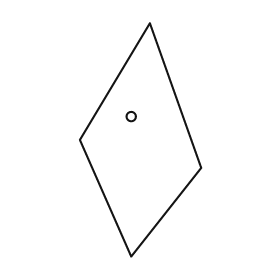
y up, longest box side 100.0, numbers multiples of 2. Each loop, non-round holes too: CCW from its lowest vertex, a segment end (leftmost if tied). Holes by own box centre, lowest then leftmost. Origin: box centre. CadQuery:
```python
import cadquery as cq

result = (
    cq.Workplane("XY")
    .moveTo(-4.0, -50.0)
    .lineTo(26.0, -12.0)
    .lineTo(4.0, 50.0)
    .lineTo(-26.0, 0.0)
    .close()
    .moveTo(-4.0, 10.0)
    .circle(2.0)
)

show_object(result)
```